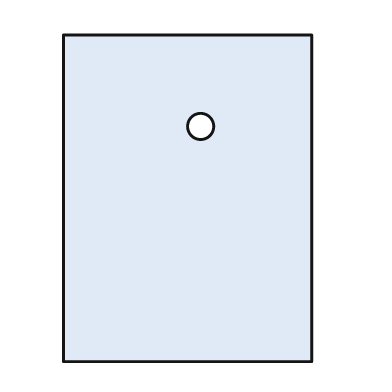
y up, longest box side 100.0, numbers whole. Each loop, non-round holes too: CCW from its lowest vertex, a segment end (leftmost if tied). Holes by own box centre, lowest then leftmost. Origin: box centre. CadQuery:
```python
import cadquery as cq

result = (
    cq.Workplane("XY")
    .moveTo(-38.0, -50.0)
    .lineTo(38.0, -50.0)
    .lineTo(38.0, 50.0)
    .lineTo(-38.0, 50.0)
    .close()
    .moveTo(4.0, 22.0)
    .circle(4.0)
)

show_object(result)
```